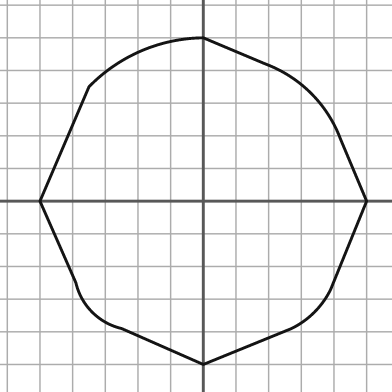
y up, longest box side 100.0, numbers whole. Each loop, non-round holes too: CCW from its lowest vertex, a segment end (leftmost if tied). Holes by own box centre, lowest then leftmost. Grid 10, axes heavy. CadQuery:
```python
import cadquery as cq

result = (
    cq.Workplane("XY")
    .moveTo(0.0, -50.0)
    .lineTo(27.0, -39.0)
    .threePointArc((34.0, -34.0), (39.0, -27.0))
    .lineTo(50.0, 0.0)
    .lineTo(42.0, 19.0)
    .threePointArc((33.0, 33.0), (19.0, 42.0))
    .lineTo(0.0, 50.0)
    .threePointArc((-19.0, 46.0), (-35.0, 35.0))
    .lineTo(-50.0, 0.0)
    .lineTo(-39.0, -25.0)
    .threePointArc((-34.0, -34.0), (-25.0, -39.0))
    .close()
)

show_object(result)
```